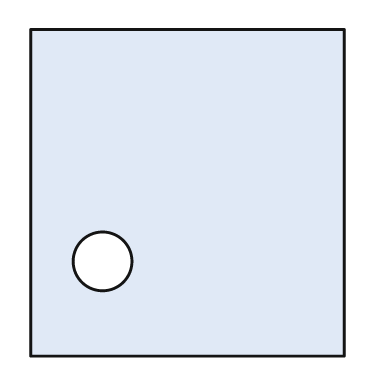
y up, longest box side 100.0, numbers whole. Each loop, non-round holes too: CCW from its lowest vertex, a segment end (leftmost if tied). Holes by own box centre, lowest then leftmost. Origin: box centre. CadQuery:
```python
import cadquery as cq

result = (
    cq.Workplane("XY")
    .moveTo(-48.0, -50.0)
    .lineTo(48.0, -50.0)
    .lineTo(48.0, 50.0)
    .lineTo(-48.0, 50.0)
    .close()
    .moveTo(-26.0, -21.0)
    .circle(9.0)
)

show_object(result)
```